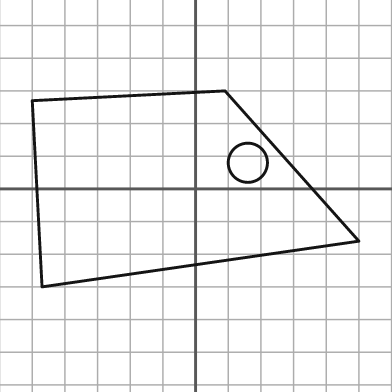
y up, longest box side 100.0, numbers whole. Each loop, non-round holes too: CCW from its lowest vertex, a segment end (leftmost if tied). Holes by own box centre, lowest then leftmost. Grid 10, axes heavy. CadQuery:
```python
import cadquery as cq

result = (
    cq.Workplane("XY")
    .moveTo(-47.0, -30.0)
    .lineTo(50.0, -16.0)
    .lineTo(9.0, 30.0)
    .lineTo(-50.0, 27.0)
    .close()
    .moveTo(16.0, 8.0)
    .circle(6.0)
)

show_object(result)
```